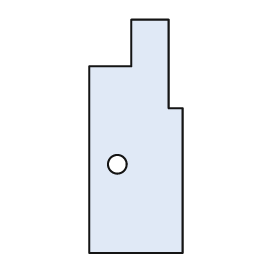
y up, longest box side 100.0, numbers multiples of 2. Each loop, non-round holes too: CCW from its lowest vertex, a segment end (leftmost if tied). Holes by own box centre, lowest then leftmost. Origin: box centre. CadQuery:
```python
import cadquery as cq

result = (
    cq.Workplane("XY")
    .moveTo(-20.0, -50.0)
    .lineTo(20.0, -50.0)
    .lineTo(20.0, 12.0)
    .lineTo(14.0, 12.0)
    .lineTo(14.0, 50.0)
    .lineTo(-2.0, 50.0)
    .lineTo(-2.0, 30.0)
    .lineTo(-20.0, 30.0)
    .close()
    .moveTo(-8.0, -12.0)
    .circle(4.0)
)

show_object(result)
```